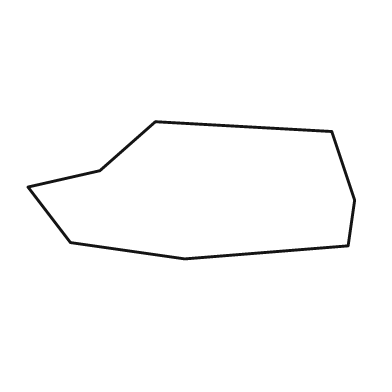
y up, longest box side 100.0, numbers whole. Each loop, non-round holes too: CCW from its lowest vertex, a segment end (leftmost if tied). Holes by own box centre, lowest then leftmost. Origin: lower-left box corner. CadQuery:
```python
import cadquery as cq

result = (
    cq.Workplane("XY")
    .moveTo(48.0, 0.0)
    .lineTo(98.0, 4.0)
    .lineTo(100.0, 18.0)
    .lineTo(93.0, 39.0)
    .lineTo(39.0, 42.0)
    .lineTo(22.0, 27.0)
    .lineTo(0.0, 22.0)
    .lineTo(13.0, 5.0)
    .close()
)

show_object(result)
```